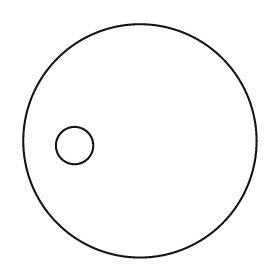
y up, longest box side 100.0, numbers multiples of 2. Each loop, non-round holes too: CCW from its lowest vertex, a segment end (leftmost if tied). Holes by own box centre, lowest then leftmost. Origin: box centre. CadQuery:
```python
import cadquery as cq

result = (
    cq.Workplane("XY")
    .moveTo(0.0, 0.0)
    .circle(50.0)
    .moveTo(-28.0, -2.0)
    .circle(8.0)
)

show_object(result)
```